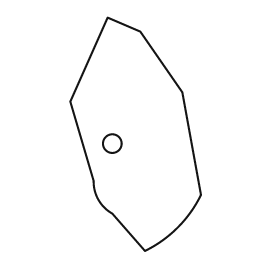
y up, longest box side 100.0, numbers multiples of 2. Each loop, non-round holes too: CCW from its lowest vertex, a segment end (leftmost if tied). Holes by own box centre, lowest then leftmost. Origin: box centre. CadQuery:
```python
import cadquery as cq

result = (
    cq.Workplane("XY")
    .moveTo(4.0, -50.0)
    .threePointArc((18.0, -40.0), (28.0, -26.0))
    .lineTo(20.0, 18.0)
    .lineTo(2.0, 44.0)
    .lineTo(-12.0, 50.0)
    .lineTo(-28.0, 14.0)
    .lineTo(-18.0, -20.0)
    .threePointArc((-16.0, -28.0), (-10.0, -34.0))
    .close()
    .moveTo(-10.0, -4.0)
    .circle(4.0)
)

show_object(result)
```